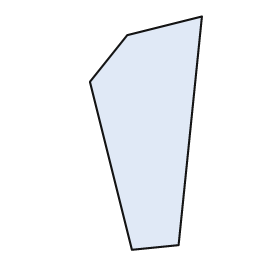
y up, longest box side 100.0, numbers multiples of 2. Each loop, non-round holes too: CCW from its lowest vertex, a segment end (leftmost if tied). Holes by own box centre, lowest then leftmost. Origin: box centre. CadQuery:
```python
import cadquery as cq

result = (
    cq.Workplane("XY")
    .moveTo(-6.0, -50.0)
    .lineTo(14.0, -48.0)
    .lineTo(24.0, 50.0)
    .lineTo(-8.0, 42.0)
    .lineTo(-24.0, 22.0)
    .close()
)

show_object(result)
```